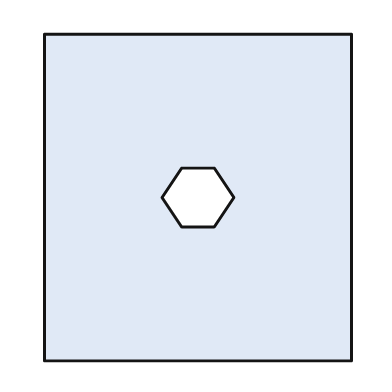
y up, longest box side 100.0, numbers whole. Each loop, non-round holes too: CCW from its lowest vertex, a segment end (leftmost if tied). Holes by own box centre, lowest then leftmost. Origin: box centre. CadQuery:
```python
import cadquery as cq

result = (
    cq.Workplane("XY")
    .moveTo(-47.0, -50.0)
    .lineTo(47.0, -50.0)
    .lineTo(47.0, 50.0)
    .lineTo(-47.0, 50.0)
    .close()
    .moveTo(-5.0, -9.0)
    .lineTo(5.0, -9.0)
    .lineTo(11.0, 0.0)
    .lineTo(5.0, 9.0)
    .lineTo(-5.0, 9.0)
    .lineTo(-11.0, 0.0)
    .close()
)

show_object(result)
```